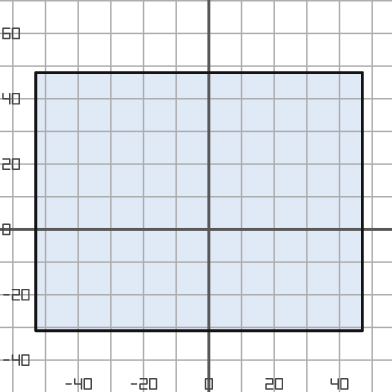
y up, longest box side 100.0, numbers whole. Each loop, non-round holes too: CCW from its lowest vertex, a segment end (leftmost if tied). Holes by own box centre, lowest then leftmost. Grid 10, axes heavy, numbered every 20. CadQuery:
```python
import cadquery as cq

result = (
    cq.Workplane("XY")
    .moveTo(-53.0, -31.0)
    .lineTo(47.0, -31.0)
    .lineTo(47.0, 48.0)
    .lineTo(-53.0, 48.0)
    .close()
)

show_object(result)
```